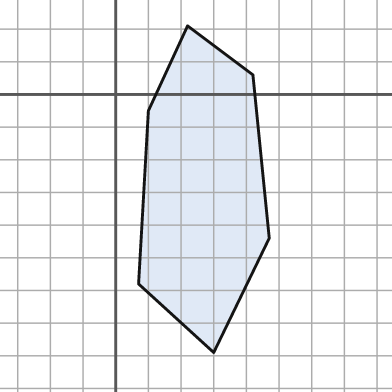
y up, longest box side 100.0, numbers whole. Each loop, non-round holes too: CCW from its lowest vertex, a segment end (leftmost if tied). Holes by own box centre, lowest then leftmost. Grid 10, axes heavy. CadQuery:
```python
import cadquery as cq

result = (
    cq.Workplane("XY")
    .moveTo(30.0, -79.0)
    .lineTo(47.0, -44.0)
    .lineTo(42.0, 6.0)
    .lineTo(22.0, 21.0)
    .lineTo(10.0, -5.0)
    .lineTo(7.0, -58.0)
    .close()
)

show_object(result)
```